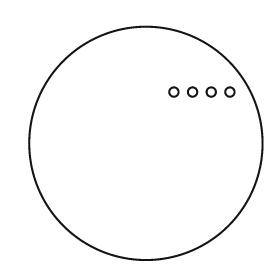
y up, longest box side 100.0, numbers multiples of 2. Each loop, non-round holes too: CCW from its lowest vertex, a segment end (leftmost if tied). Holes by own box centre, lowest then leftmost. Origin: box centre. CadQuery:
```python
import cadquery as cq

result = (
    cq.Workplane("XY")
    .moveTo(0.0, 0.0)
    .circle(50.0)
    .moveTo(12.0, 22.0)
    .circle(2.0)
    .moveTo(20.0, 22.0)
    .circle(2.0)
    .moveTo(28.0, 22.0)
    .circle(2.0)
    .moveTo(36.0, 22.0)
    .circle(2.0)
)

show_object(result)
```